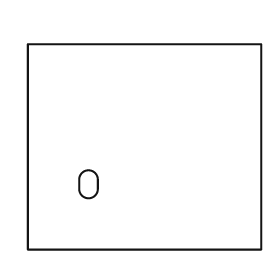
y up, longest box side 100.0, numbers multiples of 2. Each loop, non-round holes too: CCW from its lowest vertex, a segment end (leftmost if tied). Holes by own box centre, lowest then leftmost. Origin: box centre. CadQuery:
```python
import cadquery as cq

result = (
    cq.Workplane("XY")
    .moveTo(-50.0, -44.0)
    .lineTo(50.0, -44.0)
    .lineTo(50.0, 44.0)
    .lineTo(-50.0, 44.0)
    .close()
    .moveTo(-28.0, -18.0)
    .threePointArc((-24.0, -22.0), (-20.0, -18.0))
    .lineTo(-20.0, -14.0)
    .threePointArc((-24.0, -10.0), (-28.0, -14.0))
    .close()
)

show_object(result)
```